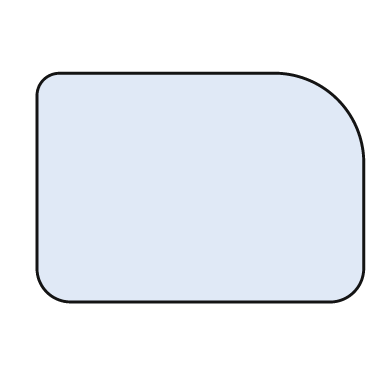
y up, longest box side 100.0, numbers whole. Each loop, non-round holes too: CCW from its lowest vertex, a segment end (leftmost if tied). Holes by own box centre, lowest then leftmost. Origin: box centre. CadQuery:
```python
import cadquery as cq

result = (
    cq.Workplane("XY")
    .moveTo(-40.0, -35.0)
    .lineTo(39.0, -35.0)
    .threePointArc((47.0, -32.0), (50.0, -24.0))
    .lineTo(50.0, 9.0)
    .threePointArc((42.0, 27.0), (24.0, 35.0))
    .lineTo(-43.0, 35.0)
    .threePointArc((-48.0, 33.0), (-50.0, 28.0))
    .lineTo(-50.0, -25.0)
    .threePointArc((-47.0, -32.0), (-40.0, -35.0))
    .close()
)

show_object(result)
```